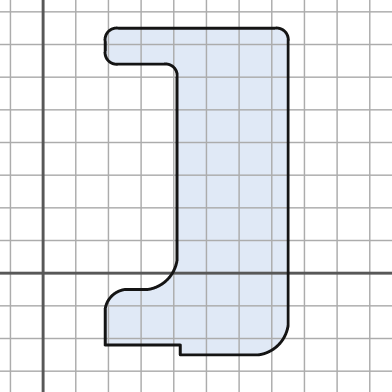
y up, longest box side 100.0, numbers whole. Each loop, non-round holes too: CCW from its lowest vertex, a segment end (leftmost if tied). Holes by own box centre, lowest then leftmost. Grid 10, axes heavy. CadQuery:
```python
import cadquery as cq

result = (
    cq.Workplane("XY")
    .moveTo(42.0, -25.0)
    .lineTo(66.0, -25.0)
    .threePointArc((72.0, -22.0), (75.0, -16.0))
    .lineTo(75.0, 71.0)
    .threePointArc((74.0, 74.0), (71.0, 75.0))
    .lineTo(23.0, 75.0)
    .threePointArc((20.0, 74.0), (19.0, 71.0))
    .lineTo(19.0, 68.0)
    .threePointArc((20.0, 65.0), (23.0, 64.0))
    .lineTo(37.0, 64.0)
    .threePointArc((40.0, 63.0), (41.0, 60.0))
    .lineTo(41.0, 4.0)
    .threePointArc((38.0, -2.0), (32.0, -5.0))
    .lineTo(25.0, -5.0)
    .threePointArc((21.0, -7.0), (19.0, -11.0))
    .lineTo(19.0, -22.0)
    .lineTo(42.0, -22.0)
    .close()
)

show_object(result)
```